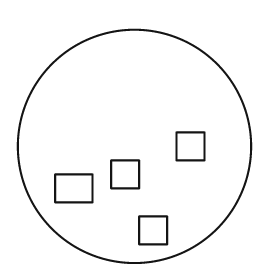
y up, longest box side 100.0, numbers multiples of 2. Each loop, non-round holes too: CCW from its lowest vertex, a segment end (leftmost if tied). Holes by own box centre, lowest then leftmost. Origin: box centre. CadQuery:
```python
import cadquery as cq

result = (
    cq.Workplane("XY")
    .moveTo(0.0, 0.0)
    .circle(50.0)
    .moveTo(2.0, -42.0)
    .lineTo(14.0, -42.0)
    .lineTo(14.0, -30.0)
    .lineTo(2.0, -30.0)
    .close()
    .moveTo(-34.0, -24.0)
    .lineTo(-18.0, -24.0)
    .lineTo(-18.0, -12.0)
    .lineTo(-34.0, -12.0)
    .close()
    .moveTo(-10.0, -18.0)
    .lineTo(2.0, -18.0)
    .lineTo(2.0, -6.0)
    .lineTo(-10.0, -6.0)
    .close()
    .moveTo(18.0, -6.0)
    .lineTo(30.0, -6.0)
    .lineTo(30.0, 6.0)
    .lineTo(18.0, 6.0)
    .close()
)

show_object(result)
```